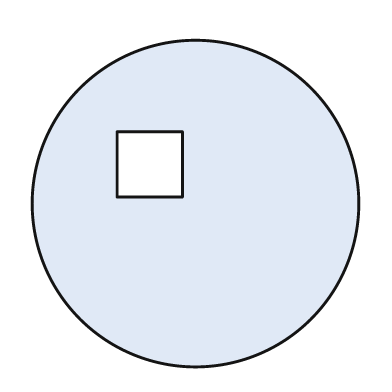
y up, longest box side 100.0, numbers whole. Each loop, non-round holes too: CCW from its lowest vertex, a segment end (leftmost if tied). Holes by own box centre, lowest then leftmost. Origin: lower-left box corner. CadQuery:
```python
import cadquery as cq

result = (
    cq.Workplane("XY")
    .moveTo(50.0, 50.0)
    .circle(50.0)
    .moveTo(26.0, 52.0)
    .lineTo(46.0, 52.0)
    .lineTo(46.0, 72.0)
    .lineTo(26.0, 72.0)
    .close()
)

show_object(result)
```